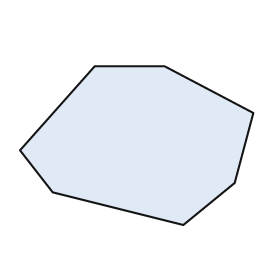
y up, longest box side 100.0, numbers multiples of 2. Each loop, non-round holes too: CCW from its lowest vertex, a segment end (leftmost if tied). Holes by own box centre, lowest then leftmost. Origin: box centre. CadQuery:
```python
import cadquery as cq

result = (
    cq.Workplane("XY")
    .moveTo(20.0, -34.0)
    .lineTo(42.0, -16.0)
    .lineTo(50.0, 14.0)
    .lineTo(12.0, 34.0)
    .lineTo(-18.0, 34.0)
    .lineTo(-50.0, -2.0)
    .lineTo(-36.0, -20.0)
    .close()
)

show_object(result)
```